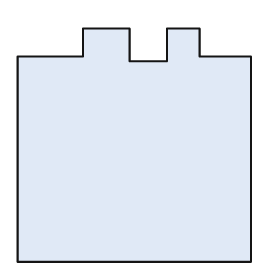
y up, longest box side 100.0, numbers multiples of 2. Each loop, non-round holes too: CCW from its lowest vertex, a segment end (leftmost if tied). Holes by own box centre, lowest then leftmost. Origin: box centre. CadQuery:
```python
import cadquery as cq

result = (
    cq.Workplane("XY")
    .moveTo(-50.0, -50.0)
    .lineTo(50.0, -50.0)
    .lineTo(50.0, 38.0)
    .lineTo(28.0, 38.0)
    .lineTo(28.0, 50.0)
    .lineTo(14.0, 50.0)
    .lineTo(14.0, 36.0)
    .lineTo(-2.0, 36.0)
    .lineTo(-2.0, 50.0)
    .lineTo(-22.0, 50.0)
    .lineTo(-22.0, 38.0)
    .lineTo(-50.0, 38.0)
    .close()
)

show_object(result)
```